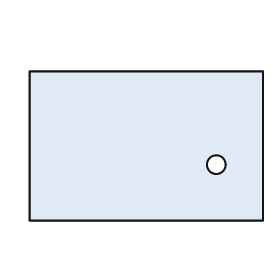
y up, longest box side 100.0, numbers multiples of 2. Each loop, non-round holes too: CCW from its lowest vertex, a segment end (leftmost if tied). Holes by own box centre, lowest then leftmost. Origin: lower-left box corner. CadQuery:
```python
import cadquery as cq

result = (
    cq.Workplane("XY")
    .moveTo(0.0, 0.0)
    .lineTo(100.0, 0.0)
    .lineTo(100.0, 64.0)
    .lineTo(0.0, 64.0)
    .close()
    .moveTo(80.0, 24.0)
    .circle(4.0)
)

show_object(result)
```